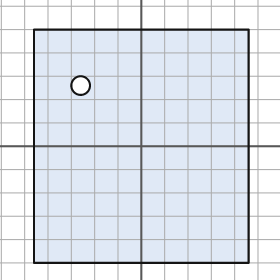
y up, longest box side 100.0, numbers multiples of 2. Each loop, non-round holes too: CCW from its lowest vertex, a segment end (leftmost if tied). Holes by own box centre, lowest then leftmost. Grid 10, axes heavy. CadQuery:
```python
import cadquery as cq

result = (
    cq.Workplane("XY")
    .moveTo(-46.0, -50.0)
    .lineTo(46.0, -50.0)
    .lineTo(46.0, 50.0)
    .lineTo(-46.0, 50.0)
    .close()
    .moveTo(-26.0, 26.0)
    .circle(4.0)
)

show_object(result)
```